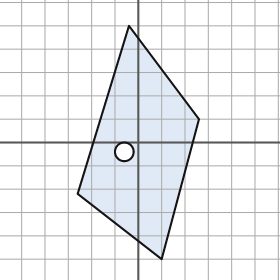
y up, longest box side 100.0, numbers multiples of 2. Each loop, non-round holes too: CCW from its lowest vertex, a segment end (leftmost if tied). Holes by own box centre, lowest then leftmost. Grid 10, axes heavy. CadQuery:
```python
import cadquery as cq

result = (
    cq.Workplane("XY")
    .moveTo(10.0, -50.0)
    .lineTo(26.0, 10.0)
    .lineTo(-4.0, 50.0)
    .lineTo(-26.0, -22.0)
    .close()
    .moveTo(-6.0, -4.0)
    .circle(4.0)
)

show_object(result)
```